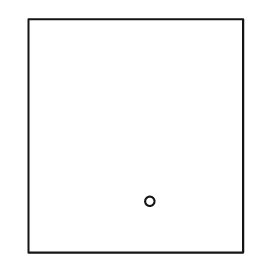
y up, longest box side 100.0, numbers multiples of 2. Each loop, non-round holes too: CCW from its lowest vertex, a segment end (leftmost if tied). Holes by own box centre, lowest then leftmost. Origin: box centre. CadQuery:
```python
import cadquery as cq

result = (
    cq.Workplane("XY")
    .moveTo(-46.0, -50.0)
    .lineTo(46.0, -50.0)
    .lineTo(46.0, 50.0)
    .lineTo(-46.0, 50.0)
    .close()
    .moveTo(6.0, -28.0)
    .circle(2.0)
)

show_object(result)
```